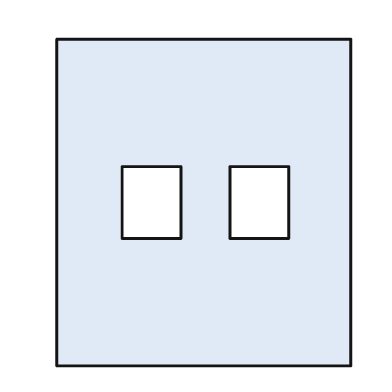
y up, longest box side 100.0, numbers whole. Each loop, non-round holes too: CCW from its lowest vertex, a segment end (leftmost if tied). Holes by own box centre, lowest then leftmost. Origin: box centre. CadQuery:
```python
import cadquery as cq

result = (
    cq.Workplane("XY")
    .moveTo(-45.0, -50.0)
    .lineTo(45.0, -50.0)
    .lineTo(45.0, 50.0)
    .lineTo(-45.0, 50.0)
    .close()
    .moveTo(-25.0, -11.0)
    .lineTo(-7.0, -11.0)
    .lineTo(-7.0, 11.0)
    .lineTo(-25.0, 11.0)
    .close()
    .moveTo(8.0, -11.0)
    .lineTo(26.0, -11.0)
    .lineTo(26.0, 11.0)
    .lineTo(8.0, 11.0)
    .close()
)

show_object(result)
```